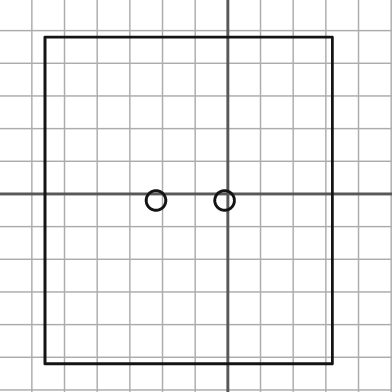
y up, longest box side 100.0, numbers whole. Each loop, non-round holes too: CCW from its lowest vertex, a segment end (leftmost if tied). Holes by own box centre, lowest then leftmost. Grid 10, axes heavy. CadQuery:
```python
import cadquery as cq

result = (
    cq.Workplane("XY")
    .moveTo(-56.0, -52.0)
    .lineTo(32.0, -52.0)
    .lineTo(32.0, 48.0)
    .lineTo(-56.0, 48.0)
    .close()
    .moveTo(-22.0, -2.0)
    .circle(3.0)
    .moveTo(-1.0, -2.0)
    .circle(3.0)
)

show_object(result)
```